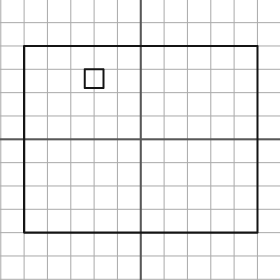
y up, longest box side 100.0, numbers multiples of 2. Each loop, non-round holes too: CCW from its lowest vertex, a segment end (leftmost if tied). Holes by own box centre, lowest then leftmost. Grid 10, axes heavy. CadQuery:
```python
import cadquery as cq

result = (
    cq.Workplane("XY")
    .moveTo(-50.0, -40.0)
    .lineTo(50.0, -40.0)
    .lineTo(50.0, 40.0)
    .lineTo(-50.0, 40.0)
    .close()
    .moveTo(-24.0, 22.0)
    .lineTo(-16.0, 22.0)
    .lineTo(-16.0, 30.0)
    .lineTo(-24.0, 30.0)
    .close()
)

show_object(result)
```